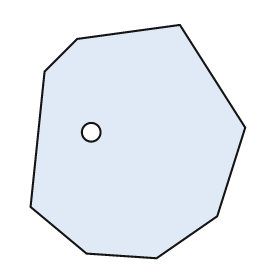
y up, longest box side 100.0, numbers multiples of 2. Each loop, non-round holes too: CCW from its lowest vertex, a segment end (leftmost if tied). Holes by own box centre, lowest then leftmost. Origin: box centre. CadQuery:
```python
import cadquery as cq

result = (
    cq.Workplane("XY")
    .moveTo(8.0, -50.0)
    .lineTo(34.0, -32.0)
    .lineTo(46.0, 6.0)
    .lineTo(18.0, 50.0)
    .lineTo(-26.0, 44.0)
    .lineTo(-40.0, 30.0)
    .lineTo(-46.0, -28.0)
    .lineTo(-22.0, -48.0)
    .close()
    .moveTo(-20.0, 4.0)
    .circle(4.0)
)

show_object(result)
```